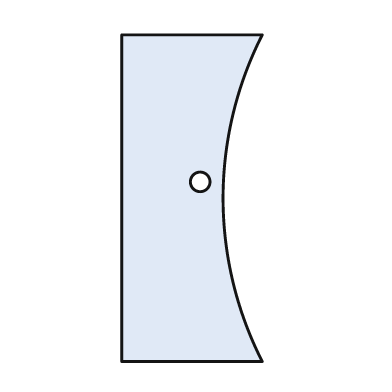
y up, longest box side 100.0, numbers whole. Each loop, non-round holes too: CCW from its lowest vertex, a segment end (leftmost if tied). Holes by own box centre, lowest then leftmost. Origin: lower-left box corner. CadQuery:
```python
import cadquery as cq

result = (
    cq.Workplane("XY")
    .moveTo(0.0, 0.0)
    .lineTo(43.0, 0.0)
    .threePointArc((31.0, 50.0), (43.0, 100.0))
    .lineTo(0.0, 100.0)
    .close()
    .moveTo(24.0, 55.0)
    .circle(3.0)
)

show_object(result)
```